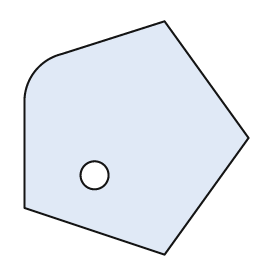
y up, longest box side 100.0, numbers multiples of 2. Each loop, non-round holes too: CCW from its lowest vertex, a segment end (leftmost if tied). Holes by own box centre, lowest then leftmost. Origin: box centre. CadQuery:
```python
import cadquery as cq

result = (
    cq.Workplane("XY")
    .moveTo(12.0, -50.0)
    .lineTo(48.0, 0.0)
    .lineTo(12.0, 50.0)
    .lineTo(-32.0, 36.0)
    .threePointArc((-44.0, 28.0), (-48.0, 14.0))
    .lineTo(-48.0, -30.0)
    .close()
    .moveTo(-18.0, -16.0)
    .circle(6.0)
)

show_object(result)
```